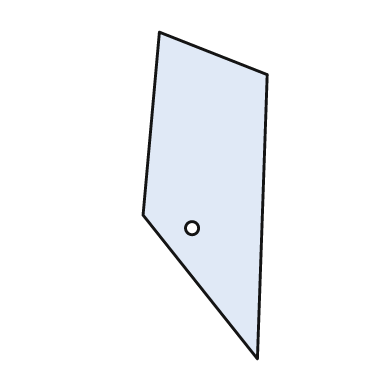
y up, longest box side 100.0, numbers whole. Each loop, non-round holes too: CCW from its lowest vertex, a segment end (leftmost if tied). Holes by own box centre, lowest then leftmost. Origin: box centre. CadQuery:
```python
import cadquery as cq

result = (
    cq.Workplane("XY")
    .moveTo(16.0, -50.0)
    .lineTo(19.0, 37.0)
    .lineTo(-14.0, 50.0)
    .lineTo(-19.0, -6.0)
    .close()
    .moveTo(-4.0, -10.0)
    .circle(2.0)
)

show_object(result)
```